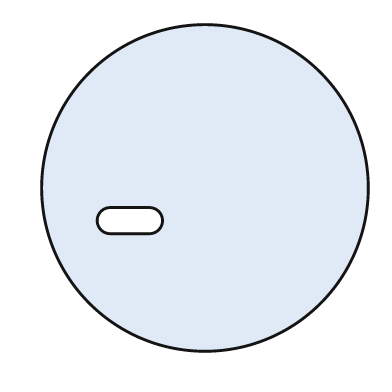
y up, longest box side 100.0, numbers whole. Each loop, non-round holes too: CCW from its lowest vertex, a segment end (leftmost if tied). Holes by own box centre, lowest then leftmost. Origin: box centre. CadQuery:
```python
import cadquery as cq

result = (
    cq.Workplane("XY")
    .moveTo(0.0, 0.0)
    .circle(50.0)
    .moveTo(-29.0, -14.0)
    .lineTo(-17.0, -14.0)
    .threePointArc((-13.0, -10.0), (-17.0, -6.0))
    .lineTo(-29.0, -6.0)
    .threePointArc((-33.0, -10.0), (-29.0, -14.0))
    .close()
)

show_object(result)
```